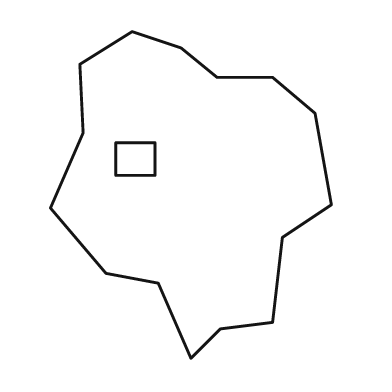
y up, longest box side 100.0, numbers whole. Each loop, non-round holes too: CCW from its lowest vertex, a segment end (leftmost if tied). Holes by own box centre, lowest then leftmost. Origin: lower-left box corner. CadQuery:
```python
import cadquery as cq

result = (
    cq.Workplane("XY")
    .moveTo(43.0, 0.0)
    .lineTo(52.0, 9.0)
    .lineTo(68.0, 11.0)
    .lineTo(71.0, 37.0)
    .lineTo(86.0, 47.0)
    .lineTo(81.0, 75.0)
    .lineTo(68.0, 86.0)
    .lineTo(51.0, 86.0)
    .lineTo(40.0, 95.0)
    .lineTo(25.0, 100.0)
    .lineTo(9.0, 90.0)
    .lineTo(10.0, 69.0)
    .lineTo(0.0, 46.0)
    .lineTo(17.0, 26.0)
    .lineTo(33.0, 23.0)
    .close()
    .moveTo(20.0, 56.0)
    .lineTo(32.0, 56.0)
    .lineTo(32.0, 66.0)
    .lineTo(20.0, 66.0)
    .close()
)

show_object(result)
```